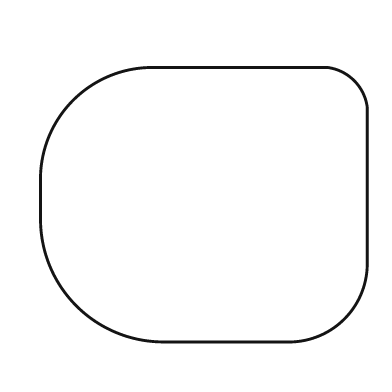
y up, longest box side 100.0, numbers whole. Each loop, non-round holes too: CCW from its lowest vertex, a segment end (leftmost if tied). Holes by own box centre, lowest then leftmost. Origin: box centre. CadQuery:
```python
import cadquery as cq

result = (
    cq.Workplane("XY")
    .moveTo(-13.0, -42.0)
    .lineTo(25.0, -42.0)
    .threePointArc((43.0, -35.0), (50.0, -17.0))
    .lineTo(50.0, 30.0)
    .threePointArc((46.0, 38.0), (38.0, 42.0))
    .lineTo(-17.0, 42.0)
    .threePointArc((-40.0, 32.0), (-50.0, 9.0))
    .lineTo(-50.0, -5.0)
    .threePointArc((-39.0, -31.0), (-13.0, -42.0))
    .close()
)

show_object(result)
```